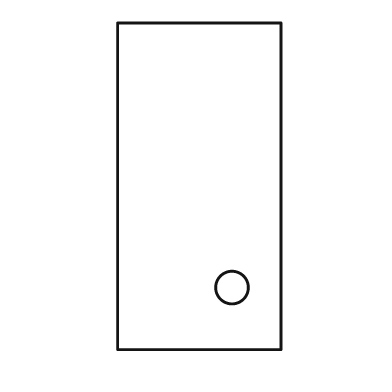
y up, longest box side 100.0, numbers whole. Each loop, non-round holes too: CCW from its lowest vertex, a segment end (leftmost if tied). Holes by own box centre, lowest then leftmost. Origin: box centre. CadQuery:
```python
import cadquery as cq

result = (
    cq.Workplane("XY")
    .moveTo(-25.0, -50.0)
    .lineTo(25.0, -50.0)
    .lineTo(25.0, 50.0)
    .lineTo(-25.0, 50.0)
    .close()
    .moveTo(10.0, -31.0)
    .circle(5.0)
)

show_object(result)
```